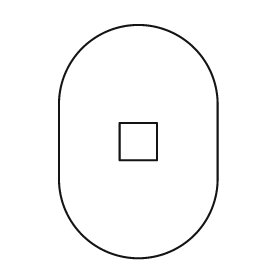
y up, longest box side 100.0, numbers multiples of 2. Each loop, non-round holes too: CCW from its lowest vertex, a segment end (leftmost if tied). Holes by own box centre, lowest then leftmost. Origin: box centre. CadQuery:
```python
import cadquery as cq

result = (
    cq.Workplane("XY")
    .moveTo(-34.0, -16.0)
    .threePointArc((0.0, -50.0), (34.0, -16.0))
    .lineTo(34.0, 16.0)
    .threePointArc((0.0, 50.0), (-34.0, 16.0))
    .close()
    .moveTo(-8.0, -8.0)
    .lineTo(8.0, -8.0)
    .lineTo(8.0, 8.0)
    .lineTo(-8.0, 8.0)
    .close()
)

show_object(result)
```